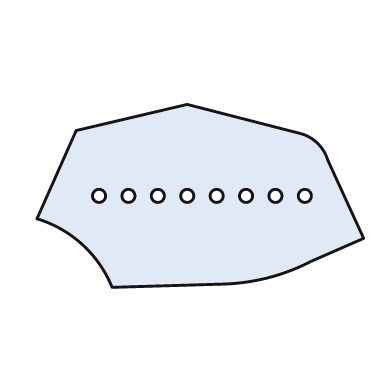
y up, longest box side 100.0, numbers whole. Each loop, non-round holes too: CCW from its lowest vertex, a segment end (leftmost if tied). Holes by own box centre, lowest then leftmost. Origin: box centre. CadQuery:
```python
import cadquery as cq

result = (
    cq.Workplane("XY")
    .moveTo(-27.0, -28.0)
    .lineTo(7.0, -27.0)
    .threePointArc((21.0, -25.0), (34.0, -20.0))
    .lineTo(50.0, -13.0)
    .lineTo(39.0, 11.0)
    .threePointArc((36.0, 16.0), (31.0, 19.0))
    .lineTo(-4.0, 28.0)
    .lineTo(-38.0, 20.0)
    .lineTo(-50.0, -7.0)
    .threePointArc((-36.0, -15.0), (-27.0, -28.0))
    .close()
    .moveTo(-31.0, 0.0)
    .circle(2.0)
    .moveTo(-22.0, 0.0)
    .circle(2.0)
    .moveTo(-13.0, 0.0)
    .circle(2.0)
    .moveTo(-4.0, 0.0)
    .circle(2.0)
    .moveTo(5.0, 0.0)
    .circle(2.0)
    .moveTo(14.0, 0.0)
    .circle(2.0)
    .moveTo(23.0, 0.0)
    .circle(2.0)
    .moveTo(32.0, 0.0)
    .circle(2.0)
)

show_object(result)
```